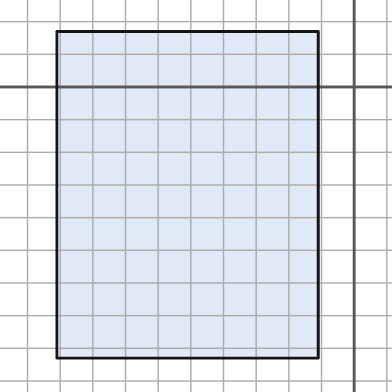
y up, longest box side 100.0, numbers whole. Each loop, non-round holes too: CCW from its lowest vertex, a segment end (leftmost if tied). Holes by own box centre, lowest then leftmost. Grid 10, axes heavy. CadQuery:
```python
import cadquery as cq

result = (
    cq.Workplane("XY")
    .moveTo(-91.0, -83.0)
    .lineTo(-11.0, -83.0)
    .lineTo(-11.0, 17.0)
    .lineTo(-91.0, 17.0)
    .close()
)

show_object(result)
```